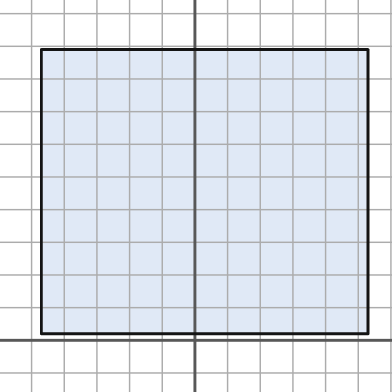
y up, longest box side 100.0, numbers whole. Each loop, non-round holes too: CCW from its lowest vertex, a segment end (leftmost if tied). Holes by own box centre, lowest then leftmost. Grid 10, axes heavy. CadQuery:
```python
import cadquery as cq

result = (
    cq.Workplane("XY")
    .moveTo(-47.0, 2.0)
    .lineTo(53.0, 2.0)
    .lineTo(53.0, 89.0)
    .lineTo(-47.0, 89.0)
    .close()
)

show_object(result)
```